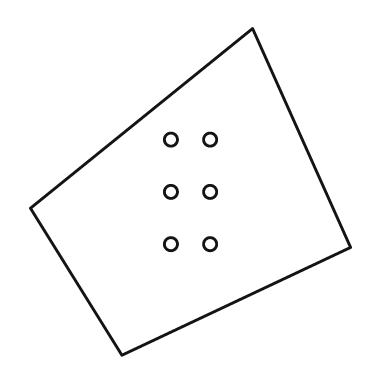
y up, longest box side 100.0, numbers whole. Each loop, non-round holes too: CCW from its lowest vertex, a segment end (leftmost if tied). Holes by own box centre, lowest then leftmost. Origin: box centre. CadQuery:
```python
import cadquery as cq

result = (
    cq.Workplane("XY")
    .moveTo(-21.0, -50.0)
    .lineTo(49.0, -17.0)
    .lineTo(19.0, 50.0)
    .lineTo(-49.0, -5.0)
    .close()
    .moveTo(-6.0, -16.0)
    .circle(2.0)
    .moveTo(6.0, -16.0)
    .circle(2.0)
    .moveTo(-6.0, 0.0)
    .circle(2.0)
    .moveTo(6.0, 0.0)
    .circle(2.0)
    .moveTo(-6.0, 16.0)
    .circle(2.0)
    .moveTo(6.0, 16.0)
    .circle(2.0)
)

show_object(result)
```